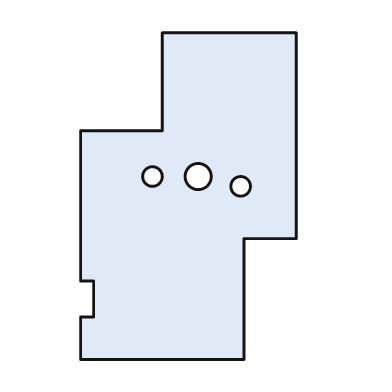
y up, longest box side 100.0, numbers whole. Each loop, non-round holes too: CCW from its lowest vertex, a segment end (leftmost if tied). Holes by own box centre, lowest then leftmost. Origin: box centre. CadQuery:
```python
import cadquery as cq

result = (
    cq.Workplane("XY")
    .moveTo(-33.0, -50.0)
    .lineTo(17.0, -50.0)
    .lineTo(17.0, -13.0)
    .lineTo(33.0, -13.0)
    .lineTo(33.0, 50.0)
    .lineTo(-8.0, 50.0)
    .lineTo(-8.0, 20.0)
    .lineTo(-33.0, 20.0)
    .lineTo(-33.0, -26.0)
    .lineTo(-29.0, -26.0)
    .lineTo(-29.0, -37.0)
    .lineTo(-33.0, -37.0)
    .close()
    .moveTo(16.0, 3.0)
    .circle(3.0)
    .moveTo(-11.0, 6.0)
    .circle(3.0)
    .moveTo(3.0, 6.0)
    .circle(4.0)
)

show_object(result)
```